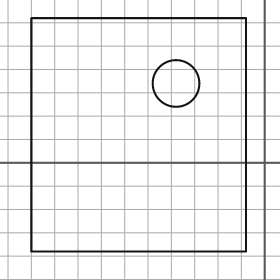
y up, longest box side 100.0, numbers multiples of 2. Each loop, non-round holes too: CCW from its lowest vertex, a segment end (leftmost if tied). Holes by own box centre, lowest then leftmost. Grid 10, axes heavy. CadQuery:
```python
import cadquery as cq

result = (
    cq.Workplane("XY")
    .moveTo(-100.0, -38.0)
    .lineTo(-8.0, -38.0)
    .lineTo(-8.0, 62.0)
    .lineTo(-100.0, 62.0)
    .close()
    .moveTo(-38.0, 34.0)
    .circle(10.0)
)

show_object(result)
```